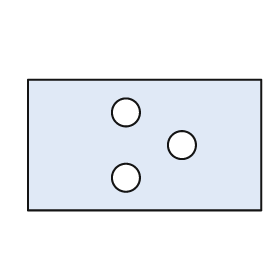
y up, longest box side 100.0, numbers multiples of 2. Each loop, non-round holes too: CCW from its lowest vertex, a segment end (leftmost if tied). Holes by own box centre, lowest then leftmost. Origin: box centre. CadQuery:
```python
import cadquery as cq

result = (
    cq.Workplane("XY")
    .moveTo(-50.0, -28.0)
    .lineTo(50.0, -28.0)
    .lineTo(50.0, 28.0)
    .lineTo(-50.0, 28.0)
    .close()
    .moveTo(-8.0, -14.0)
    .circle(6.0)
    .moveTo(16.0, 0.0)
    .circle(6.0)
    .moveTo(-8.0, 14.0)
    .circle(6.0)
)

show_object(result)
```